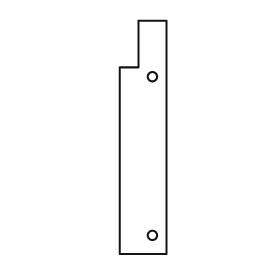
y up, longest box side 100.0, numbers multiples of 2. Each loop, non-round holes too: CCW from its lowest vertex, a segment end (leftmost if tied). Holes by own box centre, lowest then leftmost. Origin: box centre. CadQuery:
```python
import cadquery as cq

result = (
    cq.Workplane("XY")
    .moveTo(-10.0, -50.0)
    .lineTo(10.0, -50.0)
    .lineTo(10.0, 50.0)
    .lineTo(-2.0, 50.0)
    .lineTo(-2.0, 30.0)
    .lineTo(-10.0, 30.0)
    .close()
    .moveTo(4.0, -42.0)
    .circle(2.0)
    .moveTo(4.0, 26.0)
    .circle(2.0)
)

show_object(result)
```